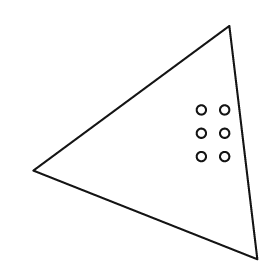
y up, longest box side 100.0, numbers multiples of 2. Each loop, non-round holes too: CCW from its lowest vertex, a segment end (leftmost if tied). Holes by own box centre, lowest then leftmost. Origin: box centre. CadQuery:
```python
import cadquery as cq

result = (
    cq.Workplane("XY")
    .moveTo(48.0, -50.0)
    .lineTo(36.0, 50.0)
    .lineTo(-48.0, -12.0)
    .close()
    .moveTo(24.0, -6.0)
    .circle(2.0)
    .moveTo(34.0, -6.0)
    .circle(2.0)
    .moveTo(24.0, 4.0)
    .circle(2.0)
    .moveTo(34.0, 4.0)
    .circle(2.0)
    .moveTo(24.0, 14.0)
    .circle(2.0)
    .moveTo(34.0, 14.0)
    .circle(2.0)
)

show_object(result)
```